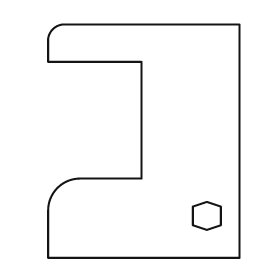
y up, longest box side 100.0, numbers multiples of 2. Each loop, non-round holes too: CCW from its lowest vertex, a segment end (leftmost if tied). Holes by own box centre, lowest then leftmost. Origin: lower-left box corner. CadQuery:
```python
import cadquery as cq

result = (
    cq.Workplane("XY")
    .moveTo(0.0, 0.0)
    .lineTo(82.0, 0.0)
    .lineTo(82.0, 100.0)
    .lineTo(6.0, 100.0)
    .threePointArc((2.0, 98.0), (0.0, 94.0))
    .lineTo(0.0, 84.0)
    .lineTo(40.0, 84.0)
    .lineTo(40.0, 34.0)
    .lineTo(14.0, 34.0)
    .threePointArc((4.0, 30.0), (0.0, 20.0))
    .close()
    .moveTo(68.0, 12.0)
    .lineTo(74.0, 14.0)
    .lineTo(74.0, 22.0)
    .lineTo(68.0, 24.0)
    .lineTo(62.0, 22.0)
    .lineTo(62.0, 14.0)
    .close()
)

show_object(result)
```